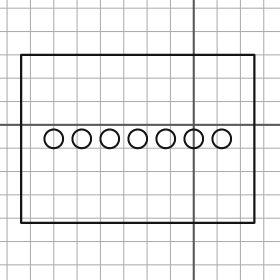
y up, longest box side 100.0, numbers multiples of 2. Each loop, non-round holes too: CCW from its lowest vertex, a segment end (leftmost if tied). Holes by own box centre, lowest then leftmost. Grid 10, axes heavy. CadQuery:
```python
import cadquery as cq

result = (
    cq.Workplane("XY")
    .moveTo(-74.0, -42.0)
    .lineTo(26.0, -42.0)
    .lineTo(26.0, 30.0)
    .lineTo(-74.0, 30.0)
    .close()
    .moveTo(-60.0, -6.0)
    .circle(4.0)
    .moveTo(-48.0, -6.0)
    .circle(4.0)
    .moveTo(-36.0, -6.0)
    .circle(4.0)
    .moveTo(-24.0, -6.0)
    .circle(4.0)
    .moveTo(-12.0, -6.0)
    .circle(4.0)
    .moveTo(0.0, -6.0)
    .circle(4.0)
    .moveTo(12.0, -6.0)
    .circle(4.0)
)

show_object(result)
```